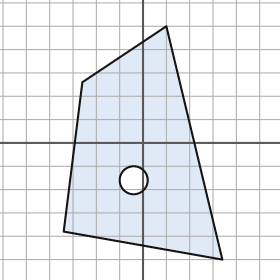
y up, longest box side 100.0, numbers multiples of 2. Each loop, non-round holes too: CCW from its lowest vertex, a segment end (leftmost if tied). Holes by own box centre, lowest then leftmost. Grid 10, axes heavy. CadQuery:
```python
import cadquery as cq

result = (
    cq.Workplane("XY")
    .moveTo(34.0, -50.0)
    .lineTo(10.0, 50.0)
    .lineTo(-26.0, 26.0)
    .lineTo(-34.0, -38.0)
    .close()
    .moveTo(-4.0, -16.0)
    .circle(6.0)
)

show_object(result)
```